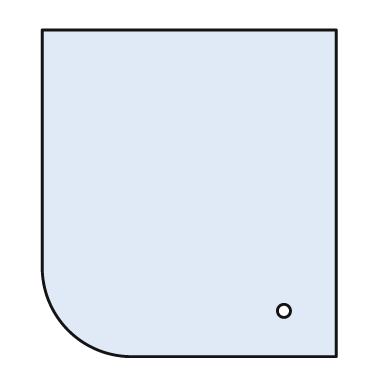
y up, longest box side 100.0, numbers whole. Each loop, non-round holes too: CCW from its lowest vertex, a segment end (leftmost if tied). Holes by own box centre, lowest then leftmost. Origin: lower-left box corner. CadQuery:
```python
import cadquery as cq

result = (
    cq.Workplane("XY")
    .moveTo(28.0, 0.0)
    .lineTo(90.0, 0.0)
    .lineTo(90.0, 100.0)
    .lineTo(0.0, 100.0)
    .lineTo(0.0, 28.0)
    .threePointArc((8.0, 8.0), (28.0, 0.0))
    .close()
    .moveTo(74.0, 14.0)
    .circle(2.0)
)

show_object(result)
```